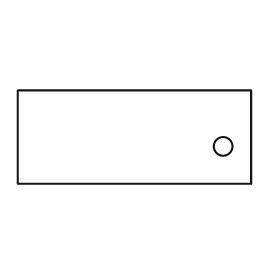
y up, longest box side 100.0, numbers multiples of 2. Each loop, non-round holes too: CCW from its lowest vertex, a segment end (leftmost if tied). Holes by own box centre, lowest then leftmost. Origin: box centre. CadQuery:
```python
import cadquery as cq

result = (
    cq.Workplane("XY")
    .moveTo(-50.0, -20.0)
    .lineTo(50.0, -20.0)
    .lineTo(50.0, 20.0)
    .lineTo(-50.0, 20.0)
    .close()
    .moveTo(38.0, -4.0)
    .circle(4.0)
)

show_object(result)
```